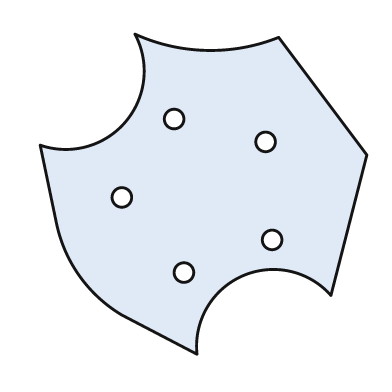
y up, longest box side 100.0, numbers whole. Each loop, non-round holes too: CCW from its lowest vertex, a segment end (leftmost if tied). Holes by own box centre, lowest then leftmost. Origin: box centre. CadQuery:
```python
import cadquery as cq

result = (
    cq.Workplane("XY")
    .moveTo(-2.0, -49.0)
    .threePointArc((12.0, -25.0), (39.0, -31.0))
    .lineTo(50.0, 12.0)
    .lineTo(23.0, 48.0)
    .threePointArc((1.0, 44.0), (-21.0, 49.0))
    .threePointArc((-24.0, 22.0), (-50.0, 15.0))
    .lineTo(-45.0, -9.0)
    .threePointArc((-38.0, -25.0), (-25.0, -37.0))
    .close()
    .moveTo(-6.0, -24.0)
    .circle(3.0)
    .moveTo(21.0, -14.0)
    .circle(3.0)
    .moveTo(-25.0, -1.0)
    .circle(3.0)
    .moveTo(19.0, 16.0)
    .circle(3.0)
    .moveTo(-9.0, 23.0)
    .circle(3.0)
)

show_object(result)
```